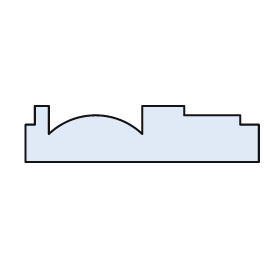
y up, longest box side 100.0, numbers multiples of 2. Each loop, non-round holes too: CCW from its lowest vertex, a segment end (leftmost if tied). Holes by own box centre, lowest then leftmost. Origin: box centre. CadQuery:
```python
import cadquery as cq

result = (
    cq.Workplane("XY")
    .moveTo(-50.0, -12.0)
    .lineTo(50.0, -12.0)
    .lineTo(50.0, 4.0)
    .lineTo(42.0, 4.0)
    .lineTo(42.0, 8.0)
    .lineTo(18.0, 8.0)
    .lineTo(18.0, 12.0)
    .lineTo(0.0, 12.0)
    .lineTo(0.0, 0.0)
    .threePointArc((-20.0, 8.0), (-40.0, 0.0))
    .lineTo(-40.0, 12.0)
    .lineTo(-46.0, 12.0)
    .lineTo(-46.0, 4.0)
    .lineTo(-50.0, 4.0)
    .close()
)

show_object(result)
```